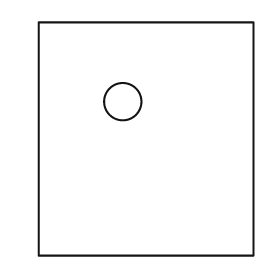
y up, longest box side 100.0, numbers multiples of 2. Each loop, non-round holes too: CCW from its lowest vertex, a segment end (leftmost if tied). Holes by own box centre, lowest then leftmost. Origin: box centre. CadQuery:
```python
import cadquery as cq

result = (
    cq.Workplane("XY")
    .moveTo(-46.0, -50.0)
    .lineTo(46.0, -50.0)
    .lineTo(46.0, 50.0)
    .lineTo(-46.0, 50.0)
    .close()
    .moveTo(-10.0, 16.0)
    .circle(8.0)
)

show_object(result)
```